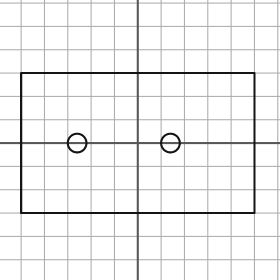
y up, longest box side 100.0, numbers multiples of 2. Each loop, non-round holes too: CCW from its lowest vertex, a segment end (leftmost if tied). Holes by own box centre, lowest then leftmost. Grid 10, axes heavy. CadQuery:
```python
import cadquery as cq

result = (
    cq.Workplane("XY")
    .moveTo(-50.0, -30.0)
    .lineTo(50.0, -30.0)
    .lineTo(50.0, 30.0)
    .lineTo(-50.0, 30.0)
    .close()
    .moveTo(-26.0, 0.0)
    .circle(4.0)
    .moveTo(14.0, 0.0)
    .circle(4.0)
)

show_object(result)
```